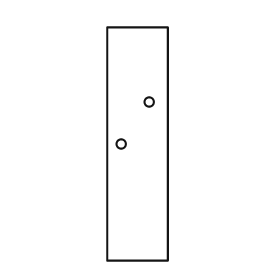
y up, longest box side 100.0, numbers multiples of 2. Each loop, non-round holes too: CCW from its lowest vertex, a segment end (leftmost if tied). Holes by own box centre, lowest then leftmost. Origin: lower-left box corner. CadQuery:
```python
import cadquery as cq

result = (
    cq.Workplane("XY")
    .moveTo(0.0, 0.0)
    .lineTo(26.0, 0.0)
    .lineTo(26.0, 100.0)
    .lineTo(0.0, 100.0)
    .close()
    .moveTo(6.0, 50.0)
    .circle(2.0)
    .moveTo(18.0, 68.0)
    .circle(2.0)
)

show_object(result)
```